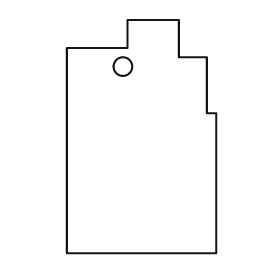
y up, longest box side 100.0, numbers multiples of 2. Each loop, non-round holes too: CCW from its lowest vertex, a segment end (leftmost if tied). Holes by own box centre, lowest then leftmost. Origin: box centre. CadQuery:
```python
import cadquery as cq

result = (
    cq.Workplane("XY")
    .moveTo(-32.0, -50.0)
    .lineTo(32.0, -50.0)
    .lineTo(32.0, 10.0)
    .lineTo(28.0, 10.0)
    .lineTo(28.0, 34.0)
    .lineTo(16.0, 34.0)
    .lineTo(16.0, 50.0)
    .lineTo(-6.0, 50.0)
    .lineTo(-6.0, 38.0)
    .lineTo(-32.0, 38.0)
    .close()
    .moveTo(-8.0, 30.0)
    .circle(4.0)
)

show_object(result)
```